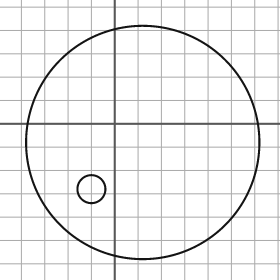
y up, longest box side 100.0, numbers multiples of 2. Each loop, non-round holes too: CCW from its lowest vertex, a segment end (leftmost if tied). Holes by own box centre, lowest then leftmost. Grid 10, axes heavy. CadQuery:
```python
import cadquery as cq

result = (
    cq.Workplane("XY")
    .moveTo(12.0, -8.0)
    .circle(50.0)
    .moveTo(-10.0, -28.0)
    .circle(6.0)
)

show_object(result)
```